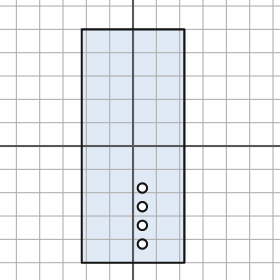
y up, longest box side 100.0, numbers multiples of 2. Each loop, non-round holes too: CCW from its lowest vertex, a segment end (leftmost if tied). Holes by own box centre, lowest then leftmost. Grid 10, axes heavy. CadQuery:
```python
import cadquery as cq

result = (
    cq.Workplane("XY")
    .moveTo(-22.0, -50.0)
    .lineTo(22.0, -50.0)
    .lineTo(22.0, 50.0)
    .lineTo(-22.0, 50.0)
    .close()
    .moveTo(4.0, -42.0)
    .circle(2.0)
    .moveTo(4.0, -34.0)
    .circle(2.0)
    .moveTo(4.0, -26.0)
    .circle(2.0)
    .moveTo(4.0, -18.0)
    .circle(2.0)
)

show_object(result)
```